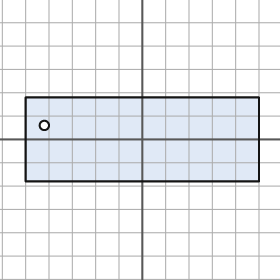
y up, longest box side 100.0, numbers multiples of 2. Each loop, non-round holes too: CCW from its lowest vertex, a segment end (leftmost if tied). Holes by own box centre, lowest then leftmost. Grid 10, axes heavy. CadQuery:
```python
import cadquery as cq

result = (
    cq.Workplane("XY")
    .moveTo(-50.0, -18.0)
    .lineTo(50.0, -18.0)
    .lineTo(50.0, 18.0)
    .lineTo(-50.0, 18.0)
    .close()
    .moveTo(-42.0, 6.0)
    .circle(2.0)
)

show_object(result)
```